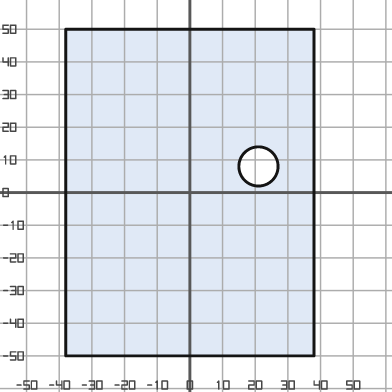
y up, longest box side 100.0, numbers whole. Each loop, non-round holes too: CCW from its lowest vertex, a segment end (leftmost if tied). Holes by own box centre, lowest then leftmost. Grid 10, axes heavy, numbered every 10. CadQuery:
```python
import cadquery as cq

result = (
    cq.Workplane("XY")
    .moveTo(-38.0, -50.0)
    .lineTo(38.0, -50.0)
    .lineTo(38.0, 50.0)
    .lineTo(-38.0, 50.0)
    .close()
    .moveTo(21.0, 8.0)
    .circle(6.0)
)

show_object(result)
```